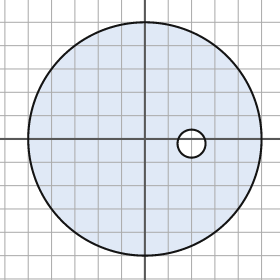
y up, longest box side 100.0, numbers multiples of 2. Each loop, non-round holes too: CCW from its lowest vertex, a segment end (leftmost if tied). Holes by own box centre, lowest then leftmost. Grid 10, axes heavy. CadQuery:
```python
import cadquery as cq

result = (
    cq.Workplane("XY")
    .moveTo(0.0, 0.0)
    .circle(50.0)
    .moveTo(20.0, -2.0)
    .circle(6.0)
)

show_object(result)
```